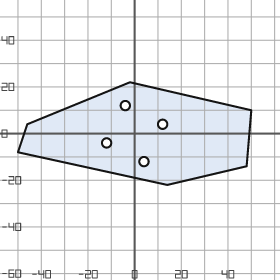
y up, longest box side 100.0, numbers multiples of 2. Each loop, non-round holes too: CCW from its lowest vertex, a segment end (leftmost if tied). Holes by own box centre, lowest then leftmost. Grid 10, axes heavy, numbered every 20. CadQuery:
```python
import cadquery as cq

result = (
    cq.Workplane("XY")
    .moveTo(14.0, -22.0)
    .lineTo(48.0, -14.0)
    .lineTo(50.0, 10.0)
    .lineTo(-2.0, 22.0)
    .lineTo(-46.0, 4.0)
    .lineTo(-50.0, -8.0)
    .close()
    .moveTo(4.0, -12.0)
    .circle(2.0)
    .moveTo(-12.0, -4.0)
    .circle(2.0)
    .moveTo(12.0, 4.0)
    .circle(2.0)
    .moveTo(-4.0, 12.0)
    .circle(2.0)
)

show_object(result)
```